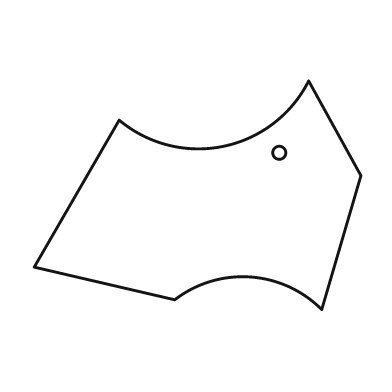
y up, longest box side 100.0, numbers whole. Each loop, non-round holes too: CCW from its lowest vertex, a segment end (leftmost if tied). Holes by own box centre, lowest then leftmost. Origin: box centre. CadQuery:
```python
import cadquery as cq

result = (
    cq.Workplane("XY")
    .moveTo(38.0, -35.0)
    .lineTo(50.0, 6.0)
    .lineTo(34.0, 35.0)
    .threePointArc((8.0, 15.0), (-24.0, 23.0))
    .lineTo(-50.0, -22.0)
    .lineTo(-7.0, -32.0)
    .threePointArc((16.0, -25.0), (38.0, -35.0))
    .close()
    .moveTo(25.0, 13.0)
    .circle(2.0)
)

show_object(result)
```